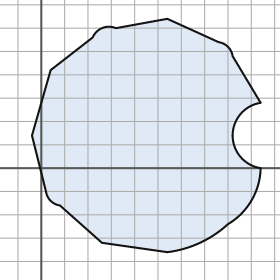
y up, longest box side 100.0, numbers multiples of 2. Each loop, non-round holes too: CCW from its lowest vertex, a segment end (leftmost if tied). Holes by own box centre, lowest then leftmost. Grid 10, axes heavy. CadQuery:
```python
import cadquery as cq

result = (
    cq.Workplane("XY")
    .moveTo(54.0, -36.0)
    .threePointArc((68.0, -32.0), (80.0, -24.0))
    .threePointArc((90.0, -14.0), (94.0, 0.0))
    .threePointArc((82.0, 14.0), (94.0, 28.0))
    .lineTo(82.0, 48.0)
    .threePointArc((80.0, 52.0), (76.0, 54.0))
    .lineTo(54.0, 64.0)
    .lineTo(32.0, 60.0)
    .threePointArc((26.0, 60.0), (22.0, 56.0))
    .lineTo(4.0, 42.0)
    .lineTo(-4.0, 14.0)
    .lineTo(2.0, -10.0)
    .threePointArc((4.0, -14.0), (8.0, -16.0))
    .lineTo(26.0, -32.0)
    .close()
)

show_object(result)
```